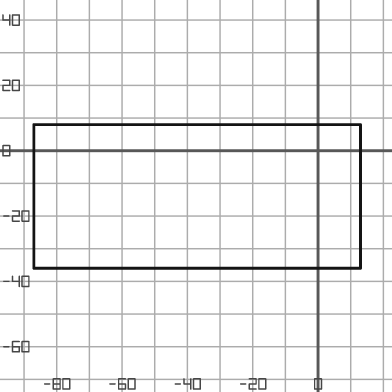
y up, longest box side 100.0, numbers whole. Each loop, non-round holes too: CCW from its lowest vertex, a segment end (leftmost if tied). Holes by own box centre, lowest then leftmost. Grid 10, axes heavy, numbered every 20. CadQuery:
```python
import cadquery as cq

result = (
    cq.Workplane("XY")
    .moveTo(-87.0, -36.0)
    .lineTo(13.0, -36.0)
    .lineTo(13.0, 8.0)
    .lineTo(-87.0, 8.0)
    .close()
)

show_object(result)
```